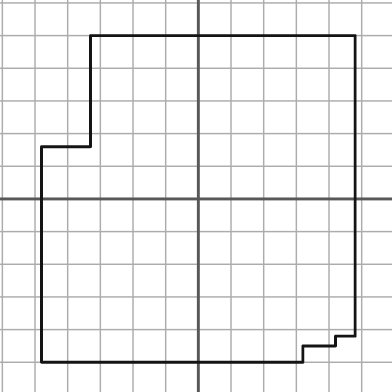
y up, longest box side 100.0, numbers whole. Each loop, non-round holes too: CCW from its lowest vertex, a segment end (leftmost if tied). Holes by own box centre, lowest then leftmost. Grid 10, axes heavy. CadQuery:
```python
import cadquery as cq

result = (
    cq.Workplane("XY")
    .moveTo(-48.0, -50.0)
    .lineTo(32.0, -50.0)
    .lineTo(32.0, -45.0)
    .lineTo(42.0, -45.0)
    .lineTo(42.0, -42.0)
    .lineTo(48.0, -42.0)
    .lineTo(48.0, 50.0)
    .lineTo(-33.0, 50.0)
    .lineTo(-33.0, 16.0)
    .lineTo(-48.0, 16.0)
    .close()
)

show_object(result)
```